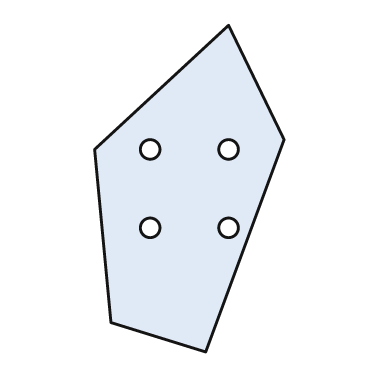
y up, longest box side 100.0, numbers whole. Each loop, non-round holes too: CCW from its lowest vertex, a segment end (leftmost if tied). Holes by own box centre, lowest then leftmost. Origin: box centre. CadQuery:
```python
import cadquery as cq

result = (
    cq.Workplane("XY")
    .moveTo(5.0, -50.0)
    .lineTo(29.0, 15.0)
    .lineTo(12.0, 50.0)
    .lineTo(-29.0, 12.0)
    .lineTo(-24.0, -41.0)
    .close()
    .moveTo(-12.0, -12.0)
    .circle(3.0)
    .moveTo(12.0, -12.0)
    .circle(3.0)
    .moveTo(-12.0, 12.0)
    .circle(3.0)
    .moveTo(12.0, 12.0)
    .circle(3.0)
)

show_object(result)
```